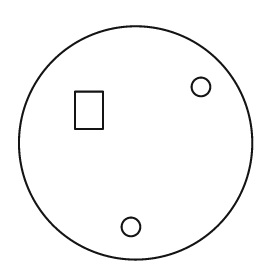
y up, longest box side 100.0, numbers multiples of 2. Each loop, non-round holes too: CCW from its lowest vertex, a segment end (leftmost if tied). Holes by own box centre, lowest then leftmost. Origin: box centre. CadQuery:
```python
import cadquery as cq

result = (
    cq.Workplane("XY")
    .moveTo(0.0, 0.0)
    .circle(50.0)
    .moveTo(-2.0, -36.0)
    .circle(4.0)
    .moveTo(-26.0, 6.0)
    .lineTo(-14.0, 6.0)
    .lineTo(-14.0, 22.0)
    .lineTo(-26.0, 22.0)
    .close()
    .moveTo(28.0, 24.0)
    .circle(4.0)
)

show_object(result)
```